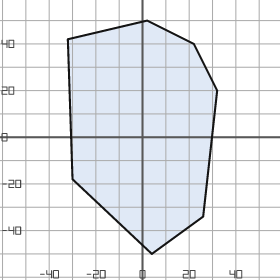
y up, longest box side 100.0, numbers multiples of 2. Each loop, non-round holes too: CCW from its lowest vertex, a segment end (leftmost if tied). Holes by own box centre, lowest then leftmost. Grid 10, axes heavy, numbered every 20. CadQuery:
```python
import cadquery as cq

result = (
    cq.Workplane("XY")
    .moveTo(4.0, -50.0)
    .lineTo(26.0, -34.0)
    .lineTo(32.0, 20.0)
    .lineTo(22.0, 40.0)
    .lineTo(2.0, 50.0)
    .lineTo(-32.0, 42.0)
    .lineTo(-30.0, -18.0)
    .close()
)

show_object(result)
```